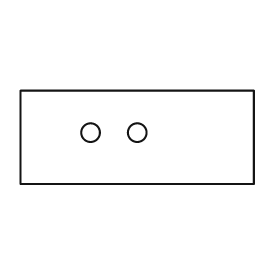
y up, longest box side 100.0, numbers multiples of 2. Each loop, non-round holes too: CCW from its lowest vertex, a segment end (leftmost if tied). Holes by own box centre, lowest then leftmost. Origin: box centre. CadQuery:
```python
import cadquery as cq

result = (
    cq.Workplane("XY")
    .moveTo(-50.0, -20.0)
    .lineTo(50.0, -20.0)
    .lineTo(50.0, 20.0)
    .lineTo(-50.0, 20.0)
    .close()
    .moveTo(-20.0, 2.0)
    .circle(4.0)
    .moveTo(0.0, 2.0)
    .circle(4.0)
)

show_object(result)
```